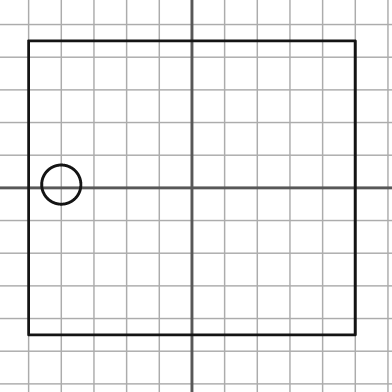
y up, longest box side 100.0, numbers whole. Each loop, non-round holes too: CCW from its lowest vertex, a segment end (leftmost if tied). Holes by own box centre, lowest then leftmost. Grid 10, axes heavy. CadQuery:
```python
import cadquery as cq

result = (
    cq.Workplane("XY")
    .moveTo(-50.0, -45.0)
    .lineTo(50.0, -45.0)
    .lineTo(50.0, 45.0)
    .lineTo(-50.0, 45.0)
    .close()
    .moveTo(-40.0, 1.0)
    .circle(6.0)
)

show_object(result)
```